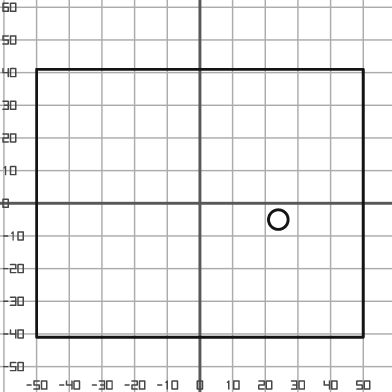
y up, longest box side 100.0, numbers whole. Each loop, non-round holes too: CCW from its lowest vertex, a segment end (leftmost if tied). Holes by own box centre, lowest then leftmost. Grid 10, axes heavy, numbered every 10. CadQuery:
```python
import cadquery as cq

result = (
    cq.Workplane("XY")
    .moveTo(-50.0, -41.0)
    .lineTo(50.0, -41.0)
    .lineTo(50.0, 41.0)
    .lineTo(-50.0, 41.0)
    .close()
    .moveTo(24.0, -5.0)
    .circle(3.0)
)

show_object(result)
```